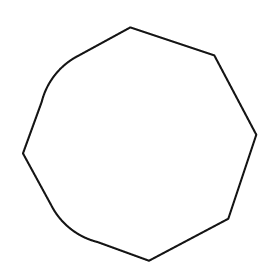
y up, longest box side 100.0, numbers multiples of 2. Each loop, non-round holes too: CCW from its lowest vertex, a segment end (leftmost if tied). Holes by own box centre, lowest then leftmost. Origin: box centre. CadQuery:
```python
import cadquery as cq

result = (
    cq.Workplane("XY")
    .moveTo(4.0, -50.0)
    .lineTo(38.0, -32.0)
    .lineTo(50.0, 4.0)
    .lineTo(32.0, 38.0)
    .lineTo(-4.0, 50.0)
    .lineTo(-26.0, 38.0)
    .threePointArc((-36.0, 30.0), (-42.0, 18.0))
    .lineTo(-50.0, -4.0)
    .lineTo(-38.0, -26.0)
    .threePointArc((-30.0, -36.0), (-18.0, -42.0))
    .close()
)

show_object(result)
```